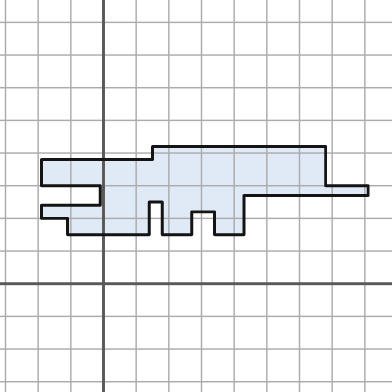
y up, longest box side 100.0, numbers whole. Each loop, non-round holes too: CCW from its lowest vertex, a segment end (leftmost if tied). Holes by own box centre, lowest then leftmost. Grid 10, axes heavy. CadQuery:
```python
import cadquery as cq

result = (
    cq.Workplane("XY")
    .moveTo(-11.0, 15.0)
    .lineTo(14.0, 15.0)
    .lineTo(14.0, 25.0)
    .lineTo(18.0, 25.0)
    .lineTo(18.0, 15.0)
    .lineTo(27.0, 15.0)
    .lineTo(27.0, 22.0)
    .lineTo(34.0, 22.0)
    .lineTo(34.0, 15.0)
    .lineTo(43.0, 15.0)
    .lineTo(43.0, 27.0)
    .lineTo(81.0, 27.0)
    .lineTo(81.0, 30.0)
    .lineTo(68.0, 30.0)
    .lineTo(68.0, 42.0)
    .lineTo(15.0, 42.0)
    .lineTo(15.0, 38.0)
    .lineTo(-19.0, 38.0)
    .lineTo(-19.0, 30.0)
    .lineTo(-1.0, 30.0)
    .lineTo(-1.0, 24.0)
    .lineTo(-19.0, 24.0)
    .lineTo(-19.0, 20.0)
    .lineTo(-11.0, 20.0)
    .close()
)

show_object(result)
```